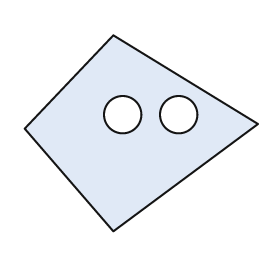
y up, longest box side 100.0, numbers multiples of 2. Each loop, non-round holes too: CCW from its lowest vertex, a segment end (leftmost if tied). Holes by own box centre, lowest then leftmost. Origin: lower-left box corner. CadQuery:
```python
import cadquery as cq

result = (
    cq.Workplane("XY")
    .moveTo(38.0, 0.0)
    .lineTo(100.0, 46.0)
    .lineTo(38.0, 84.0)
    .lineTo(0.0, 44.0)
    .close()
    .moveTo(42.0, 50.0)
    .circle(8.0)
    .moveTo(66.0, 50.0)
    .circle(8.0)
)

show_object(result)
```